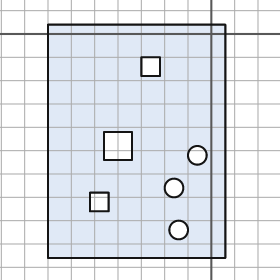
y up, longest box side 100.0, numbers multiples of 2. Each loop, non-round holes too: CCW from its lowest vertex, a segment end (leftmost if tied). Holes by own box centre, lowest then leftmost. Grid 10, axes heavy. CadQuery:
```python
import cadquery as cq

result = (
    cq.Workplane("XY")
    .moveTo(-70.0, -96.0)
    .lineTo(6.0, -96.0)
    .lineTo(6.0, 4.0)
    .lineTo(-70.0, 4.0)
    .close()
    .moveTo(-14.0, -84.0)
    .circle(4.0)
    .moveTo(-52.0, -76.0)
    .lineTo(-44.0, -76.0)
    .lineTo(-44.0, -68.0)
    .lineTo(-52.0, -68.0)
    .close()
    .moveTo(-16.0, -66.0)
    .circle(4.0)
    .moveTo(-6.0, -52.0)
    .circle(4.0)
    .moveTo(-46.0, -54.0)
    .lineTo(-34.0, -54.0)
    .lineTo(-34.0, -42.0)
    .lineTo(-46.0, -42.0)
    .close()
    .moveTo(-30.0, -18.0)
    .lineTo(-22.0, -18.0)
    .lineTo(-22.0, -10.0)
    .lineTo(-30.0, -10.0)
    .close()
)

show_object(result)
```